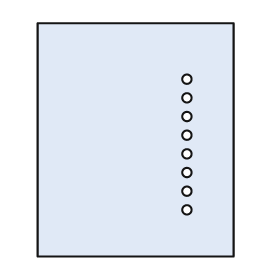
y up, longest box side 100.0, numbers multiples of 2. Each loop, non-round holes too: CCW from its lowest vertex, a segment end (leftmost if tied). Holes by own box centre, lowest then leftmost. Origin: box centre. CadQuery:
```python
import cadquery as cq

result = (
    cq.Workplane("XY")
    .moveTo(-42.0, -50.0)
    .lineTo(42.0, -50.0)
    .lineTo(42.0, 50.0)
    .lineTo(-42.0, 50.0)
    .close()
    .moveTo(22.0, -30.0)
    .circle(2.0)
    .moveTo(22.0, -22.0)
    .circle(2.0)
    .moveTo(22.0, -14.0)
    .circle(2.0)
    .moveTo(22.0, -6.0)
    .circle(2.0)
    .moveTo(22.0, 2.0)
    .circle(2.0)
    .moveTo(22.0, 10.0)
    .circle(2.0)
    .moveTo(22.0, 18.0)
    .circle(2.0)
    .moveTo(22.0, 26.0)
    .circle(2.0)
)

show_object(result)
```